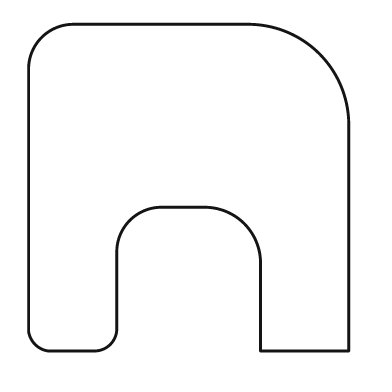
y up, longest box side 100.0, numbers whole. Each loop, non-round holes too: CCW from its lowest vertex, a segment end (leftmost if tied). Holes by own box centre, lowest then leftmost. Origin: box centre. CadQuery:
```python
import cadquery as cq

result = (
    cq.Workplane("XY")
    .moveTo(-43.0, -50.0)
    .lineTo(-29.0, -50.0)
    .threePointArc((-24.0, -48.0), (-22.0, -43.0))
    .lineTo(-22.0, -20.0)
    .threePointArc((-18.0, -10.0), (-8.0, -6.0))
    .lineTo(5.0, -6.0)
    .threePointArc((17.0, -11.0), (22.0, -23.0))
    .lineTo(22.0, -50.0)
    .lineTo(49.0, -50.0)
    .lineTo(49.0, 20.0)
    .threePointArc((40.0, 41.0), (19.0, 50.0))
    .lineTo(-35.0, 50.0)
    .threePointArc((-45.0, 46.0), (-49.0, 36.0))
    .lineTo(-49.0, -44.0)
    .threePointArc((-47.0, -48.0), (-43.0, -50.0))
    .close()
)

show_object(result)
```